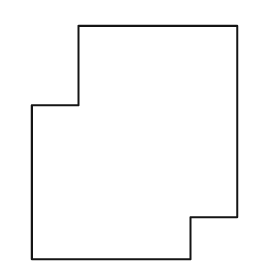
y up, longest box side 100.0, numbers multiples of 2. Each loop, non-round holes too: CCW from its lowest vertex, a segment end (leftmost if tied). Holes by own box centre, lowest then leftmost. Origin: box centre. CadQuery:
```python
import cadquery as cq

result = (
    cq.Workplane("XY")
    .moveTo(-44.0, -50.0)
    .lineTo(24.0, -50.0)
    .lineTo(24.0, -32.0)
    .lineTo(44.0, -32.0)
    .lineTo(44.0, 50.0)
    .lineTo(-24.0, 50.0)
    .lineTo(-24.0, 16.0)
    .lineTo(-44.0, 16.0)
    .close()
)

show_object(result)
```